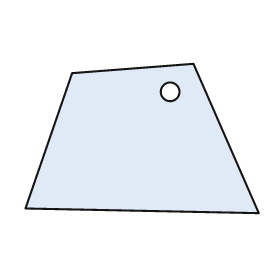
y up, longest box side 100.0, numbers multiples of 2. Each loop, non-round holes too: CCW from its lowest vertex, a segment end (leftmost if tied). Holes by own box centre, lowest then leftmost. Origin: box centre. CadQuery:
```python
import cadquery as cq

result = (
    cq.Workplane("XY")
    .moveTo(50.0, -32.0)
    .lineTo(22.0, 32.0)
    .lineTo(-30.0, 28.0)
    .lineTo(-50.0, -30.0)
    .close()
    .moveTo(12.0, 20.0)
    .circle(4.0)
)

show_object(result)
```